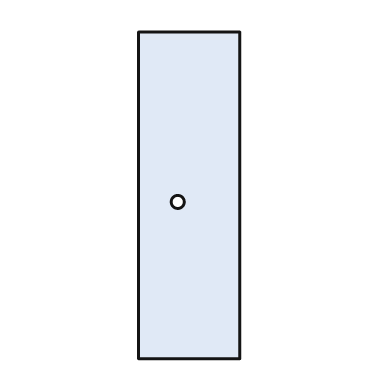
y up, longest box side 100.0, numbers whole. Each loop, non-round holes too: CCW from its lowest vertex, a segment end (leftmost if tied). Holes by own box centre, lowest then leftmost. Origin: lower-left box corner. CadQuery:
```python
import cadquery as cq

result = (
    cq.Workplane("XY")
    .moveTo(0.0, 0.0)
    .lineTo(31.0, 0.0)
    .lineTo(31.0, 100.0)
    .lineTo(0.0, 100.0)
    .close()
    .moveTo(12.0, 48.0)
    .circle(2.0)
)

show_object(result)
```